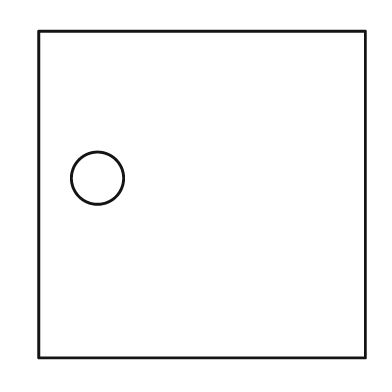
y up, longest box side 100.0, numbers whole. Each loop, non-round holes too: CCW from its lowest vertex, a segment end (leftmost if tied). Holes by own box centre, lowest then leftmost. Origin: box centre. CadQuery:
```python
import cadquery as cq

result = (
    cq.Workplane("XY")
    .moveTo(-50.0, -50.0)
    .lineTo(50.0, -50.0)
    .lineTo(50.0, 50.0)
    .lineTo(-50.0, 50.0)
    .close()
    .moveTo(-32.0, 5.0)
    .circle(8.0)
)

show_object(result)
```